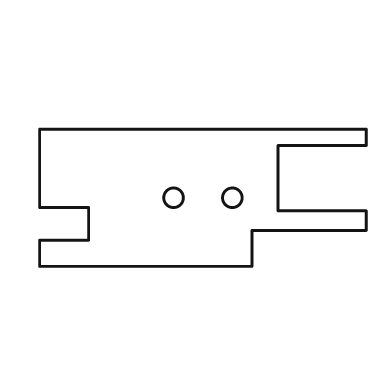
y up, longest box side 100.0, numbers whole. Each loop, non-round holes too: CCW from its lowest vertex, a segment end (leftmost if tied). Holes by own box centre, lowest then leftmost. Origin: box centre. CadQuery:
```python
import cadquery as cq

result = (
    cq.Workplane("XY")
    .moveTo(-50.0, -21.0)
    .lineTo(15.0, -21.0)
    .lineTo(15.0, -10.0)
    .lineTo(50.0, -10.0)
    .lineTo(50.0, -4.0)
    .lineTo(23.0, -4.0)
    .lineTo(23.0, 16.0)
    .lineTo(50.0, 16.0)
    .lineTo(50.0, 21.0)
    .lineTo(-50.0, 21.0)
    .lineTo(-50.0, -3.0)
    .lineTo(-35.0, -3.0)
    .lineTo(-35.0, -13.0)
    .lineTo(-50.0, -13.0)
    .close()
    .moveTo(-9.0, 0.0)
    .circle(3.0)
    .moveTo(9.0, 0.0)
    .circle(3.0)
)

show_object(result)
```